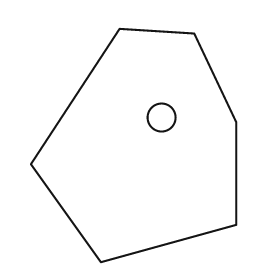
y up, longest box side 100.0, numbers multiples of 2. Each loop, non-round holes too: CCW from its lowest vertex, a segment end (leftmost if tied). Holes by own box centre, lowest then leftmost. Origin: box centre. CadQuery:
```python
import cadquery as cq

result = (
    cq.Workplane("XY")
    .moveTo(-14.0, -50.0)
    .lineTo(44.0, -34.0)
    .lineTo(44.0, 10.0)
    .lineTo(26.0, 48.0)
    .lineTo(-6.0, 50.0)
    .lineTo(-44.0, -8.0)
    .close()
    .moveTo(12.0, 12.0)
    .circle(6.0)
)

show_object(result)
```